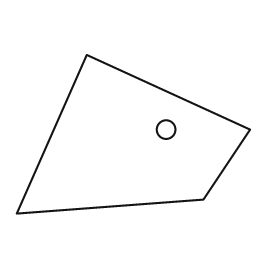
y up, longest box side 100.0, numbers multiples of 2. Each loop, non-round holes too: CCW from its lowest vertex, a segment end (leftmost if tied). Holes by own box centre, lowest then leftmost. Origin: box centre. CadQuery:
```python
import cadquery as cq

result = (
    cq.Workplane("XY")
    .moveTo(-50.0, -34.0)
    .lineTo(30.0, -28.0)
    .lineTo(50.0, 2.0)
    .lineTo(-20.0, 34.0)
    .close()
    .moveTo(14.0, 2.0)
    .circle(4.0)
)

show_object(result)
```